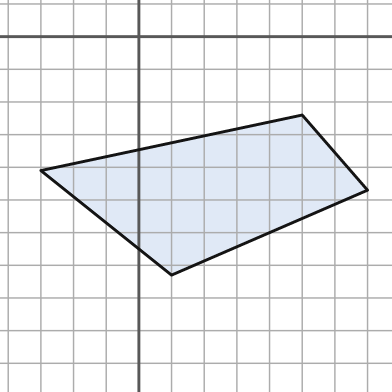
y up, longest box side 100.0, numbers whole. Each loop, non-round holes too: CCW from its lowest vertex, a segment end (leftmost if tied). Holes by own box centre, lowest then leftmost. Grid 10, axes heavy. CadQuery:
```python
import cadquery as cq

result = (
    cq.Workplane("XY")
    .moveTo(10.0, -73.0)
    .lineTo(70.0, -47.0)
    .lineTo(50.0, -24.0)
    .lineTo(-30.0, -41.0)
    .close()
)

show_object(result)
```